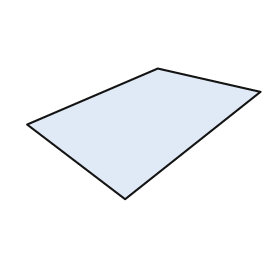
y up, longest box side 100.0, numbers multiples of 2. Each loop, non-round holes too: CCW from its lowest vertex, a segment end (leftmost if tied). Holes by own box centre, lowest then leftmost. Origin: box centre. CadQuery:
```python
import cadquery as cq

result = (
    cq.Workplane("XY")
    .moveTo(-8.0, -28.0)
    .lineTo(50.0, 18.0)
    .lineTo(6.0, 28.0)
    .lineTo(-50.0, 4.0)
    .close()
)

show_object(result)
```